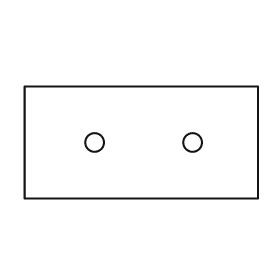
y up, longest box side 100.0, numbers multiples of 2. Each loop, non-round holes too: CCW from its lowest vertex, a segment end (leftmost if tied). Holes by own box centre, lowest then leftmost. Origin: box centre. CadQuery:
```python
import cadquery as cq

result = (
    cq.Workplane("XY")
    .moveTo(-50.0, -24.0)
    .lineTo(50.0, -24.0)
    .lineTo(50.0, 24.0)
    .lineTo(-50.0, 24.0)
    .close()
    .moveTo(-20.0, 0.0)
    .circle(4.0)
    .moveTo(22.0, 0.0)
    .circle(4.0)
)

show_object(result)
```